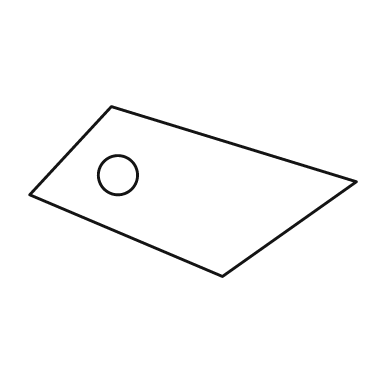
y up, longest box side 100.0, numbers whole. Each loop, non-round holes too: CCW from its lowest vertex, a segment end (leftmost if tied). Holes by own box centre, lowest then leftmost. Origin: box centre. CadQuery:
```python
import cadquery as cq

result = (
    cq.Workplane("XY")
    .moveTo(9.0, -26.0)
    .lineTo(50.0, 3.0)
    .lineTo(-25.0, 26.0)
    .lineTo(-50.0, -1.0)
    .close()
    .moveTo(-23.0, 5.0)
    .circle(6.0)
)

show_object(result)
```